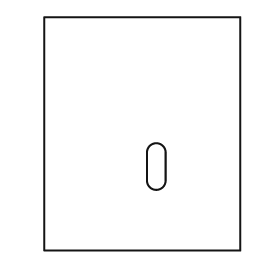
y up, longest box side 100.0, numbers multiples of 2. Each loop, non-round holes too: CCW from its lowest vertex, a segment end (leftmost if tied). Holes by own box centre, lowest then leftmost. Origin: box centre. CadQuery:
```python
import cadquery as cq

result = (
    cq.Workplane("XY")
    .moveTo(-42.0, -50.0)
    .lineTo(42.0, -50.0)
    .lineTo(42.0, 50.0)
    .lineTo(-42.0, 50.0)
    .close()
    .moveTo(2.0, -20.0)
    .threePointArc((6.0, -24.0), (10.0, -20.0))
    .lineTo(10.0, -8.0)
    .threePointArc((6.0, -4.0), (2.0, -8.0))
    .close()
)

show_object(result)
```